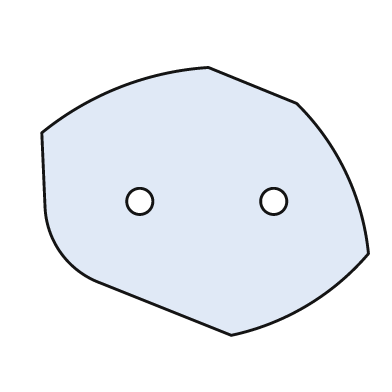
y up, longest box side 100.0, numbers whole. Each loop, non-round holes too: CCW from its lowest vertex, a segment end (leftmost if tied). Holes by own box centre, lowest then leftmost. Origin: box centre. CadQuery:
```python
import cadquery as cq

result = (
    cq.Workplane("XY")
    .moveTo(8.0, -41.0)
    .threePointArc((31.0, -32.0), (50.0, -16.0))
    .threePointArc((43.0, 9.0), (28.0, 30.0))
    .lineTo(1.0, 41.0)
    .threePointArc((-26.0, 35.0), (-50.0, 21.0))
    .lineTo(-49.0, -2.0)
    .threePointArc((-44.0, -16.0), (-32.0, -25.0))
    .close()
    .moveTo(-20.0, 0.0)
    .circle(4.0)
    .moveTo(21.0, 0.0)
    .circle(4.0)
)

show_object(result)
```